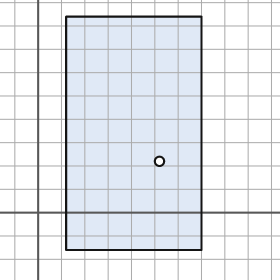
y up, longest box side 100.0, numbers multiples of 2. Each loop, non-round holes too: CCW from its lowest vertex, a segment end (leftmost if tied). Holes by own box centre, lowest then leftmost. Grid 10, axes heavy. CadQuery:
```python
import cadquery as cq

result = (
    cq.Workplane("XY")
    .moveTo(12.0, -16.0)
    .lineTo(70.0, -16.0)
    .lineTo(70.0, 84.0)
    .lineTo(12.0, 84.0)
    .close()
    .moveTo(52.0, 22.0)
    .circle(2.0)
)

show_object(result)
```